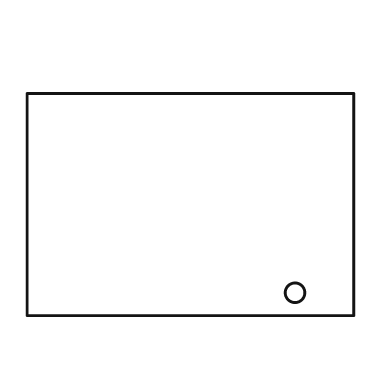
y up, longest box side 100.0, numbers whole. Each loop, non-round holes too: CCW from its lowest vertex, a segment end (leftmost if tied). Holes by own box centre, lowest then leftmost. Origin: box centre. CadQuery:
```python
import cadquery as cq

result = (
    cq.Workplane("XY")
    .moveTo(-50.0, -34.0)
    .lineTo(50.0, -34.0)
    .lineTo(50.0, 34.0)
    .lineTo(-50.0, 34.0)
    .close()
    .moveTo(32.0, -27.0)
    .circle(3.0)
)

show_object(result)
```